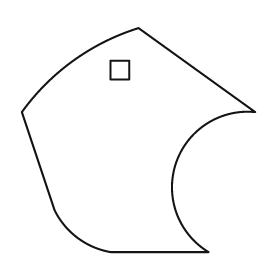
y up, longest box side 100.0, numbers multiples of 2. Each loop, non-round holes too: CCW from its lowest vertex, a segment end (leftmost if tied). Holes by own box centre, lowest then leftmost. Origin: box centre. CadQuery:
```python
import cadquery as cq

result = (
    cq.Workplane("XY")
    .moveTo(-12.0, -48.0)
    .lineTo(30.0, -48.0)
    .threePointArc((16.0, -10.0), (50.0, 12.0))
    .lineTo(0.0, 48.0)
    .threePointArc((-28.0, 34.0), (-50.0, 12.0))
    .lineTo(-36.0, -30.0)
    .threePointArc((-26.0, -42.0), (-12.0, -48.0))
    .close()
    .moveTo(-12.0, 26.0)
    .lineTo(-4.0, 26.0)
    .lineTo(-4.0, 34.0)
    .lineTo(-12.0, 34.0)
    .close()
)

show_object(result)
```